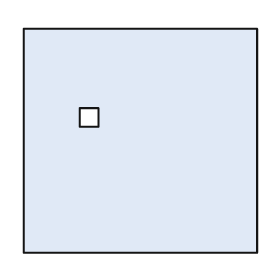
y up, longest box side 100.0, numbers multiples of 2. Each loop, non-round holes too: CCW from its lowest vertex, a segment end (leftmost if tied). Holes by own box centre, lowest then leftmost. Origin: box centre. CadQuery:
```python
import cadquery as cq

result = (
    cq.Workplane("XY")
    .moveTo(-50.0, -48.0)
    .lineTo(50.0, -48.0)
    .lineTo(50.0, 48.0)
    .lineTo(-50.0, 48.0)
    .close()
    .moveTo(-26.0, 6.0)
    .lineTo(-18.0, 6.0)
    .lineTo(-18.0, 14.0)
    .lineTo(-26.0, 14.0)
    .close()
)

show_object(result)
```